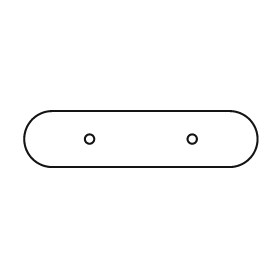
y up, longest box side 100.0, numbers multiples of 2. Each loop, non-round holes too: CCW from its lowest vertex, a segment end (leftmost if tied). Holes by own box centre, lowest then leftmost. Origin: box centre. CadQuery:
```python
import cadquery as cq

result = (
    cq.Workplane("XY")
    .moveTo(-38.0, -12.0)
    .lineTo(38.0, -12.0)
    .threePointArc((50.0, 0.0), (38.0, 12.0))
    .lineTo(-38.0, 12.0)
    .threePointArc((-50.0, 0.0), (-38.0, -12.0))
    .close()
    .moveTo(-22.0, 0.0)
    .circle(2.0)
    .moveTo(22.0, 0.0)
    .circle(2.0)
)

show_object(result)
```